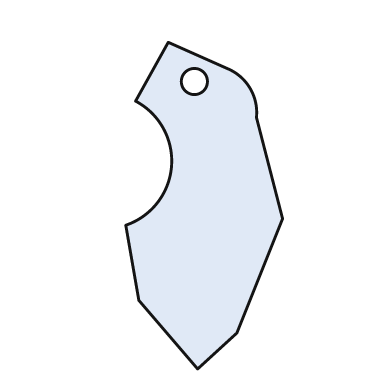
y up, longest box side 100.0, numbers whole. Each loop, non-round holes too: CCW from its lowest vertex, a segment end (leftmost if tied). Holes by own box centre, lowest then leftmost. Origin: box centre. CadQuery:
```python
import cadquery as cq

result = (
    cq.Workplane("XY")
    .moveTo(-2.0, -50.0)
    .lineTo(10.0, -39.0)
    .lineTo(24.0, -4.0)
    .lineTo(16.0, 27.0)
    .threePointArc((14.0, 36.0), (7.0, 42.0))
    .lineTo(-11.0, 50.0)
    .lineTo(-21.0, 32.0)
    .threePointArc((-10.0, 12.0), (-24.0, -6.0))
    .lineTo(-20.0, -29.0)
    .close()
    .moveTo(-3.0, 38.0)
    .circle(4.0)
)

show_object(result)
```